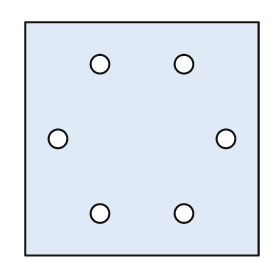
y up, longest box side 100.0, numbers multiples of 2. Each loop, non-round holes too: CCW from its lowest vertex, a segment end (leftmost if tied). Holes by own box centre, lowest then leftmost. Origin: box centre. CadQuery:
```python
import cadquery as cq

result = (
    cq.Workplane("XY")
    .moveTo(-50.0, -50.0)
    .lineTo(50.0, -50.0)
    .lineTo(50.0, 50.0)
    .lineTo(-50.0, 50.0)
    .close()
    .moveTo(-18.0, -32.0)
    .circle(4.0)
    .moveTo(18.0, -32.0)
    .circle(4.0)
    .moveTo(-36.0, 0.0)
    .circle(4.0)
    .moveTo(36.0, 0.0)
    .circle(4.0)
    .moveTo(-18.0, 32.0)
    .circle(4.0)
    .moveTo(18.0, 32.0)
    .circle(4.0)
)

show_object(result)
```